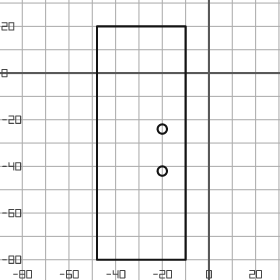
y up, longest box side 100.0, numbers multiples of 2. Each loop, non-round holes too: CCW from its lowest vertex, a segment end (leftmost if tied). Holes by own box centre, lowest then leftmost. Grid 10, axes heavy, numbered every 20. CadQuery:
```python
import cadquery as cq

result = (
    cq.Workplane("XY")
    .moveTo(-48.0, -80.0)
    .lineTo(-10.0, -80.0)
    .lineTo(-10.0, 20.0)
    .lineTo(-48.0, 20.0)
    .close()
    .moveTo(-20.0, -42.0)
    .circle(2.0)
    .moveTo(-20.0, -24.0)
    .circle(2.0)
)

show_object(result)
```